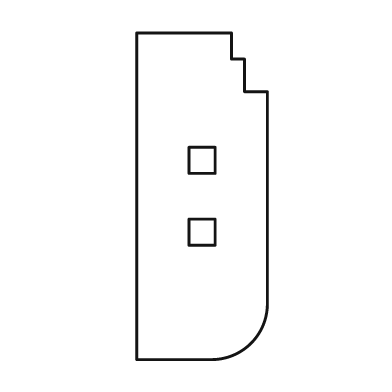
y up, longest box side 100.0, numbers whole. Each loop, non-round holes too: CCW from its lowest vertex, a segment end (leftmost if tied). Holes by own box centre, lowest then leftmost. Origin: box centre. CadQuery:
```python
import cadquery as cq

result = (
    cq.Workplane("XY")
    .moveTo(-20.0, -50.0)
    .lineTo(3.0, -50.0)
    .threePointArc((15.0, -45.0), (20.0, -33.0))
    .lineTo(20.0, 32.0)
    .lineTo(13.0, 32.0)
    .lineTo(13.0, 42.0)
    .lineTo(9.0, 42.0)
    .lineTo(9.0, 50.0)
    .lineTo(-20.0, 50.0)
    .close()
    .moveTo(-4.0, -15.0)
    .lineTo(4.0, -15.0)
    .lineTo(4.0, -7.0)
    .lineTo(-4.0, -7.0)
    .close()
    .moveTo(-4.0, 7.0)
    .lineTo(4.0, 7.0)
    .lineTo(4.0, 15.0)
    .lineTo(-4.0, 15.0)
    .close()
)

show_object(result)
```